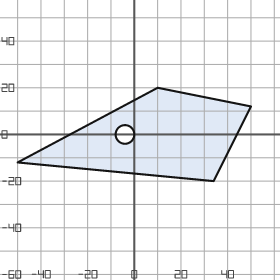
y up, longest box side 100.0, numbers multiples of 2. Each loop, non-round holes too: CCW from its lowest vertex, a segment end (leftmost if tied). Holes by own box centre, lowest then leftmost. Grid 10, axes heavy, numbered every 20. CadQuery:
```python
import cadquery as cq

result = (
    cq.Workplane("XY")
    .moveTo(34.0, -20.0)
    .lineTo(50.0, 12.0)
    .lineTo(10.0, 20.0)
    .lineTo(-50.0, -12.0)
    .close()
    .moveTo(-4.0, 0.0)
    .circle(4.0)
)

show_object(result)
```